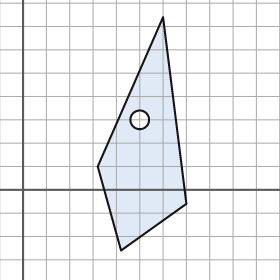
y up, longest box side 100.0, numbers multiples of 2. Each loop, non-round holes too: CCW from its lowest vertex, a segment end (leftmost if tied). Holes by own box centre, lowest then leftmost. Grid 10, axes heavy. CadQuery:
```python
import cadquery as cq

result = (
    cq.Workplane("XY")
    .moveTo(42.0, -26.0)
    .lineTo(70.0, -6.0)
    .lineTo(60.0, 74.0)
    .lineTo(32.0, 10.0)
    .close()
    .moveTo(50.0, 30.0)
    .circle(4.0)
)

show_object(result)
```